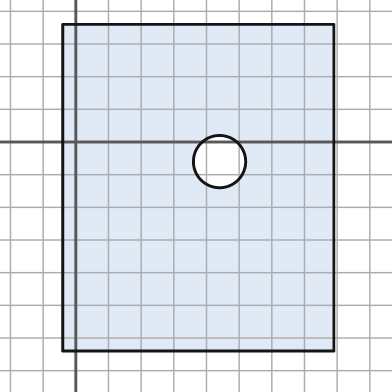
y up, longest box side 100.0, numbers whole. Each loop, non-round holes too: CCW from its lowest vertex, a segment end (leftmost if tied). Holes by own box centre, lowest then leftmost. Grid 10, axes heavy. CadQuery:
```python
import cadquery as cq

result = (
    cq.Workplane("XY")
    .moveTo(-4.0, -64.0)
    .lineTo(79.0, -64.0)
    .lineTo(79.0, 36.0)
    .lineTo(-4.0, 36.0)
    .close()
    .moveTo(44.0, -6.0)
    .circle(8.0)
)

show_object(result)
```